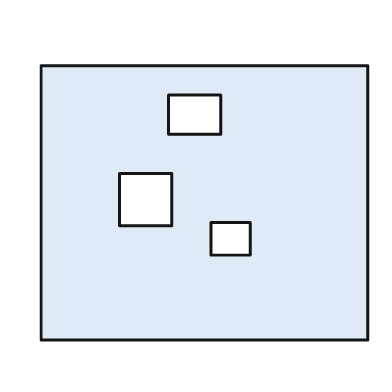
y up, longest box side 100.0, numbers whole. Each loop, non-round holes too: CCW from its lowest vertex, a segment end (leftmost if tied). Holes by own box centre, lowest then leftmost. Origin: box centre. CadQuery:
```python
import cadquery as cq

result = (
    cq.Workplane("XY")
    .moveTo(-50.0, -42.0)
    .lineTo(50.0, -42.0)
    .lineTo(50.0, 42.0)
    .lineTo(-50.0, 42.0)
    .close()
    .moveTo(2.0, -16.0)
    .lineTo(14.0, -16.0)
    .lineTo(14.0, -6.0)
    .lineTo(2.0, -6.0)
    .close()
    .moveTo(-26.0, -7.0)
    .lineTo(-10.0, -7.0)
    .lineTo(-10.0, 9.0)
    .lineTo(-26.0, 9.0)
    .close()
    .moveTo(-11.0, 21.0)
    .lineTo(5.0, 21.0)
    .lineTo(5.0, 33.0)
    .lineTo(-11.0, 33.0)
    .close()
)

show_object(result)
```